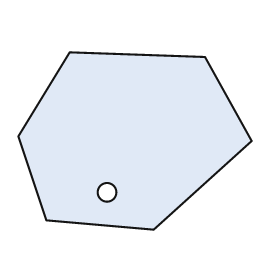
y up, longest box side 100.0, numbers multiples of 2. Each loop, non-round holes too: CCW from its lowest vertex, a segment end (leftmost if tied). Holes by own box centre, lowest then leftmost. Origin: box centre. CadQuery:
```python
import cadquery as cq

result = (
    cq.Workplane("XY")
    .moveTo(8.0, -38.0)
    .lineTo(50.0, 0.0)
    .lineTo(30.0, 36.0)
    .lineTo(-28.0, 38.0)
    .lineTo(-50.0, 2.0)
    .lineTo(-38.0, -34.0)
    .close()
    .moveTo(-12.0, -22.0)
    .circle(4.0)
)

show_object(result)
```